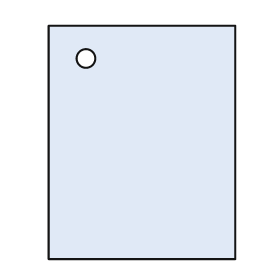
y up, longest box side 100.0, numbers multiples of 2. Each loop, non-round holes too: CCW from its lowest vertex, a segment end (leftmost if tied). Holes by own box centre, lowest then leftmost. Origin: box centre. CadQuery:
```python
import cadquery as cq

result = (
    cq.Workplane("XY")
    .moveTo(-40.0, -50.0)
    .lineTo(40.0, -50.0)
    .lineTo(40.0, 50.0)
    .lineTo(-40.0, 50.0)
    .close()
    .moveTo(-24.0, 36.0)
    .circle(4.0)
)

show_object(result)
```